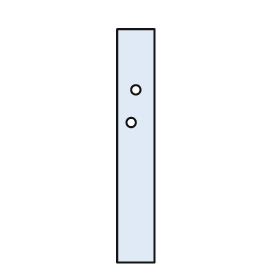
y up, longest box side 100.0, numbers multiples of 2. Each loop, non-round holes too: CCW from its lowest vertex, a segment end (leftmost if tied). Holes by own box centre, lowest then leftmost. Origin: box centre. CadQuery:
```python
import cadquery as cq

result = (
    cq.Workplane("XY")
    .moveTo(-8.0, -50.0)
    .lineTo(8.0, -50.0)
    .lineTo(8.0, 50.0)
    .lineTo(-8.0, 50.0)
    .close()
    .moveTo(-2.0, 10.0)
    .circle(2.0)
    .moveTo(0.0, 24.0)
    .circle(2.0)
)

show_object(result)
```